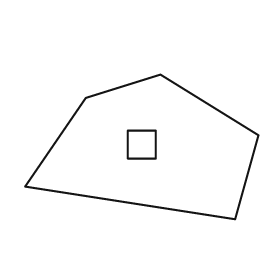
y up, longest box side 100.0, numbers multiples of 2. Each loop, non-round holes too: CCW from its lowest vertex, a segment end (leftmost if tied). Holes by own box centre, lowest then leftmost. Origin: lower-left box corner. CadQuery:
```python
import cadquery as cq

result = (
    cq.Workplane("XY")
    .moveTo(90.0, 0.0)
    .lineTo(100.0, 36.0)
    .lineTo(58.0, 62.0)
    .lineTo(26.0, 52.0)
    .lineTo(0.0, 14.0)
    .close()
    .moveTo(44.0, 26.0)
    .lineTo(56.0, 26.0)
    .lineTo(56.0, 38.0)
    .lineTo(44.0, 38.0)
    .close()
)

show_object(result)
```